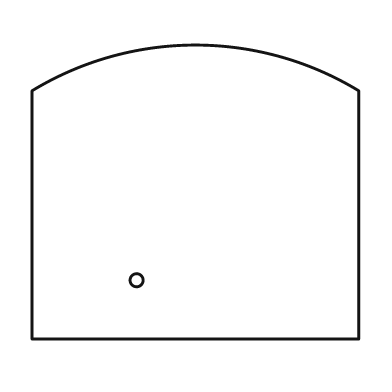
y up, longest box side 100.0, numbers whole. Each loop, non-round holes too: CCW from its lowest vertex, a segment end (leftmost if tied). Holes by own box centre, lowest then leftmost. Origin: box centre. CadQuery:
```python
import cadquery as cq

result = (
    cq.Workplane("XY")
    .moveTo(-50.0, -45.0)
    .lineTo(50.0, -45.0)
    .lineTo(50.0, 31.0)
    .threePointArc((0.0, 45.0), (-50.0, 31.0))
    .close()
    .moveTo(-18.0, -27.0)
    .circle(2.0)
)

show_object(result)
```